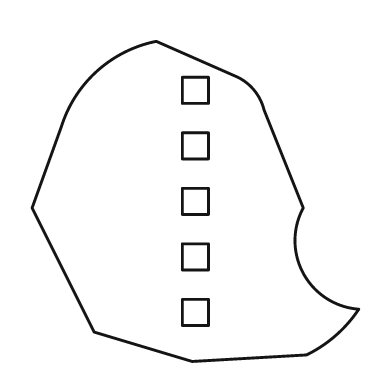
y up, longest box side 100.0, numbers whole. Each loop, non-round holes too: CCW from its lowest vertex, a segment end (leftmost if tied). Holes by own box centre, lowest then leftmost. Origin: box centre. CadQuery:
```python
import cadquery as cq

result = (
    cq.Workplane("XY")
    .moveTo(-1.0, -49.0)
    .lineTo(34.0, -47.0)
    .threePointArc((43.0, -41.0), (50.0, -33.0))
    .threePointArc((33.0, -22.0), (33.0, -2.0))
    .lineTo(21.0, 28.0)
    .threePointArc((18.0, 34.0), (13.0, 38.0))
    .lineTo(-12.0, 49.0)
    .threePointArc((-30.0, 40.0), (-41.0, 23.0))
    .lineTo(-50.0, -2.0)
    .lineTo(-31.0, -40.0)
    .close()
    .moveTo(-4.0, -38.0)
    .lineTo(4.0, -38.0)
    .lineTo(4.0, -30.0)
    .lineTo(-4.0, -30.0)
    .close()
    .moveTo(-4.0, -21.0)
    .lineTo(4.0, -21.0)
    .lineTo(4.0, -13.0)
    .lineTo(-4.0, -13.0)
    .close()
    .moveTo(-4.0, -4.0)
    .lineTo(4.0, -4.0)
    .lineTo(4.0, 4.0)
    .lineTo(-4.0, 4.0)
    .close()
    .moveTo(-4.0, 13.0)
    .lineTo(4.0, 13.0)
    .lineTo(4.0, 21.0)
    .lineTo(-4.0, 21.0)
    .close()
    .moveTo(-4.0, 30.0)
    .lineTo(4.0, 30.0)
    .lineTo(4.0, 38.0)
    .lineTo(-4.0, 38.0)
    .close()
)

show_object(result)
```